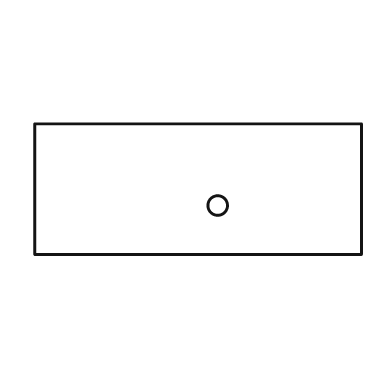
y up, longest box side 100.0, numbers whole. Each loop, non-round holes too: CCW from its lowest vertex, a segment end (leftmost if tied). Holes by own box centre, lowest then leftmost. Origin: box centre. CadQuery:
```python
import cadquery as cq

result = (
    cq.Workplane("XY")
    .moveTo(-50.0, -20.0)
    .lineTo(50.0, -20.0)
    .lineTo(50.0, 20.0)
    .lineTo(-50.0, 20.0)
    .close()
    .moveTo(6.0, -5.0)
    .circle(3.0)
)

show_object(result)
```